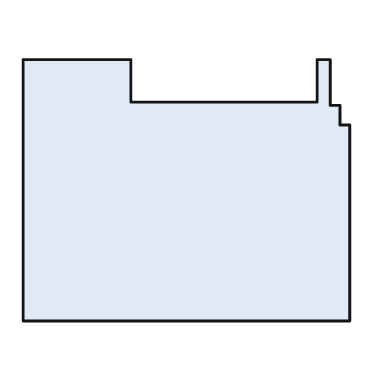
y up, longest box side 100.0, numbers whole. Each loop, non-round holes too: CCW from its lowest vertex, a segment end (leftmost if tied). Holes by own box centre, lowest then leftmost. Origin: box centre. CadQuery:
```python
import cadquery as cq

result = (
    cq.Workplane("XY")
    .moveTo(-50.0, -40.0)
    .lineTo(50.0, -40.0)
    .lineTo(50.0, 20.0)
    .lineTo(47.0, 20.0)
    .lineTo(47.0, 26.0)
    .lineTo(44.0, 26.0)
    .lineTo(44.0, 40.0)
    .lineTo(40.0, 40.0)
    .lineTo(40.0, 27.0)
    .lineTo(-17.0, 27.0)
    .lineTo(-17.0, 40.0)
    .lineTo(-50.0, 40.0)
    .close()
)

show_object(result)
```